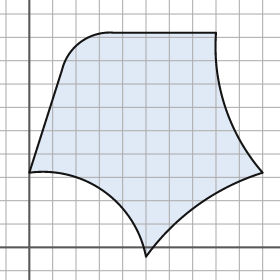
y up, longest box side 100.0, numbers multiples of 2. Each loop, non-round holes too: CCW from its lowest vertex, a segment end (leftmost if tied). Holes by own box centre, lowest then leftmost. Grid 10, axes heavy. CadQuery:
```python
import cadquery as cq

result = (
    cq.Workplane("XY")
    .moveTo(50.0, -4.0)
    .threePointArc((72.0, 18.0), (100.0, 32.0))
    .threePointArc((84.0, 60.0), (80.0, 92.0))
    .lineTo(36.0, 92.0)
    .threePointArc((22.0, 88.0), (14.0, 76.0))
    .lineTo(0.0, 32.0)
    .threePointArc((32.0, 24.0), (50.0, -4.0))
    .close()
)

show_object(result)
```